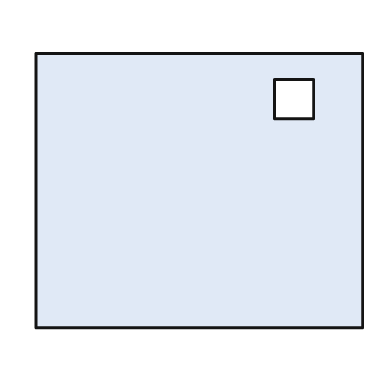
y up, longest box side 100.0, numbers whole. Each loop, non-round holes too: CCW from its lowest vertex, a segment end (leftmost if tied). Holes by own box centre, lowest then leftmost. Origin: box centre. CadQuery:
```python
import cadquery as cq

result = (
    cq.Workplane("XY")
    .moveTo(-50.0, -42.0)
    .lineTo(50.0, -42.0)
    .lineTo(50.0, 42.0)
    .lineTo(-50.0, 42.0)
    .close()
    .moveTo(23.0, 22.0)
    .lineTo(35.0, 22.0)
    .lineTo(35.0, 34.0)
    .lineTo(23.0, 34.0)
    .close()
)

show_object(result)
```